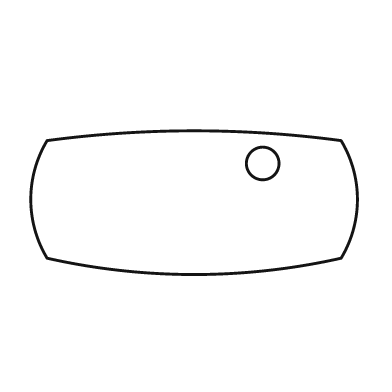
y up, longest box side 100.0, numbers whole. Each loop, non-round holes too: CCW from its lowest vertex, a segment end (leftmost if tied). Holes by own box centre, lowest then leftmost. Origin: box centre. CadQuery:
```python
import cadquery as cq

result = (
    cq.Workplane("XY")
    .moveTo(-45.0, -17.0)
    .threePointArc((0.0, -22.0), (45.0, -17.0))
    .threePointArc((50.0, 1.0), (45.0, 19.0))
    .threePointArc((0.0, 22.0), (-45.0, 19.0))
    .threePointArc((-50.0, 1.0), (-45.0, -17.0))
    .close()
    .moveTo(21.0, 12.0)
    .circle(5.0)
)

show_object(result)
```